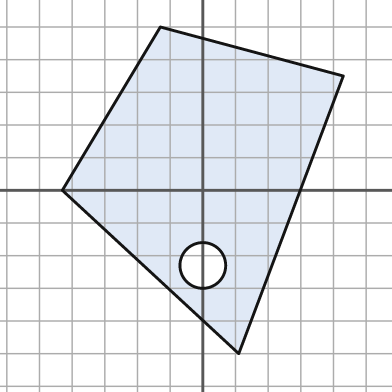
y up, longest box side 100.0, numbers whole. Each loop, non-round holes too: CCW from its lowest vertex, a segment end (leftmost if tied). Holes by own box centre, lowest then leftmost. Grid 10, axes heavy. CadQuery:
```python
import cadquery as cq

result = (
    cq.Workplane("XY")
    .moveTo(11.0, -50.0)
    .lineTo(43.0, 35.0)
    .lineTo(-13.0, 50.0)
    .lineTo(-43.0, 0.0)
    .close()
    .moveTo(0.0, -23.0)
    .circle(7.0)
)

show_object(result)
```